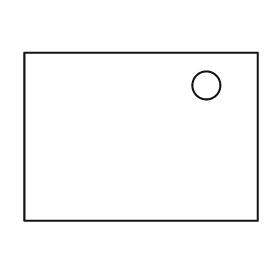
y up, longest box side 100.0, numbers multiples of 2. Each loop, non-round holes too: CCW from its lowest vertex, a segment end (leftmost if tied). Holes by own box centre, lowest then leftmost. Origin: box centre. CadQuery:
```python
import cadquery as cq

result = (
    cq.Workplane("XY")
    .moveTo(-50.0, -36.0)
    .lineTo(50.0, -36.0)
    .lineTo(50.0, 36.0)
    .lineTo(-50.0, 36.0)
    .close()
    .moveTo(28.0, 22.0)
    .circle(6.0)
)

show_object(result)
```